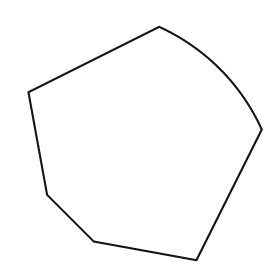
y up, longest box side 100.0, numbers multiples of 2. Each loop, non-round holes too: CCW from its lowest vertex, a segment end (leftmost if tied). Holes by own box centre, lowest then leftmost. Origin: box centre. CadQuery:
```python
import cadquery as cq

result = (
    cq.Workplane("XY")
    .moveTo(22.0, -50.0)
    .lineTo(50.0, 6.0)
    .threePointArc((32.0, 32.0), (6.0, 50.0))
    .lineTo(-50.0, 22.0)
    .lineTo(-42.0, -22.0)
    .lineTo(-22.0, -42.0)
    .close()
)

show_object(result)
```